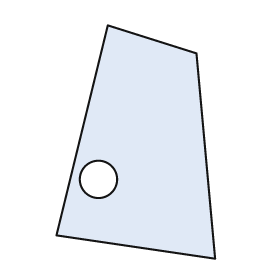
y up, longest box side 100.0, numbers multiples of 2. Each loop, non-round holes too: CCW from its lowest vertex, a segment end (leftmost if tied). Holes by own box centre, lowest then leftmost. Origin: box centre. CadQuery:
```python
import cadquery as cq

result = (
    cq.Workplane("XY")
    .moveTo(34.0, -50.0)
    .lineTo(26.0, 38.0)
    .lineTo(-12.0, 50.0)
    .lineTo(-34.0, -40.0)
    .close()
    .moveTo(-16.0, -16.0)
    .circle(8.0)
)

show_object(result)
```